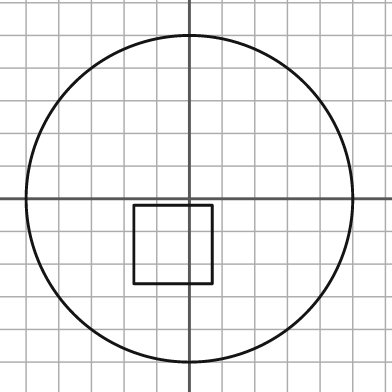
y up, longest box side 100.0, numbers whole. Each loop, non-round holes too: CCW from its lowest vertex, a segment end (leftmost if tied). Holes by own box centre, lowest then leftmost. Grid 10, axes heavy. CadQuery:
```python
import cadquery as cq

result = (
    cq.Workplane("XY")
    .moveTo(0.0, 0.0)
    .circle(50.0)
    .moveTo(-17.0, -26.0)
    .lineTo(7.0, -26.0)
    .lineTo(7.0, -2.0)
    .lineTo(-17.0, -2.0)
    .close()
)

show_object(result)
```